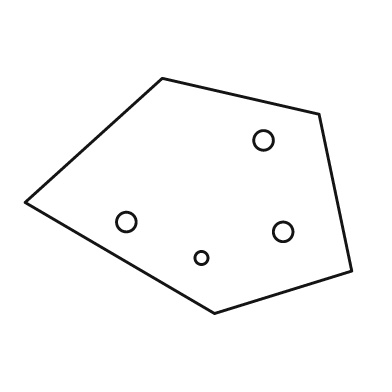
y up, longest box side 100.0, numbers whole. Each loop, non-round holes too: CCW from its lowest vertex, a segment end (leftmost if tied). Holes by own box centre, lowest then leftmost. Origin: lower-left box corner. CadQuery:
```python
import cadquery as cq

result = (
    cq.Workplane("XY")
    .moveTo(58.0, 0.0)
    .lineTo(100.0, 13.0)
    .lineTo(90.0, 61.0)
    .lineTo(42.0, 72.0)
    .lineTo(0.0, 34.0)
    .close()
    .moveTo(54.0, 17.0)
    .circle(2.0)
    .moveTo(79.0, 25.0)
    .circle(3.0)
    .moveTo(31.0, 28.0)
    .circle(3.0)
    .moveTo(73.0, 53.0)
    .circle(3.0)
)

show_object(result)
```